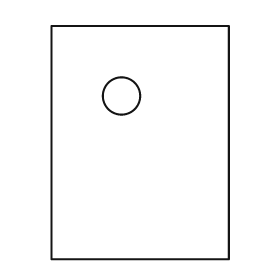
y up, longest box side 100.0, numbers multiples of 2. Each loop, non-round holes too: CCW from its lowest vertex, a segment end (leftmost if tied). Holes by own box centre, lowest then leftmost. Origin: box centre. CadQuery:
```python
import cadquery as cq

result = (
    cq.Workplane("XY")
    .moveTo(-38.0, -50.0)
    .lineTo(38.0, -50.0)
    .lineTo(38.0, 50.0)
    .lineTo(-38.0, 50.0)
    .close()
    .moveTo(-8.0, 20.0)
    .circle(8.0)
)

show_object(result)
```